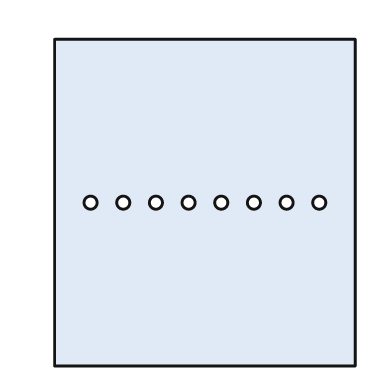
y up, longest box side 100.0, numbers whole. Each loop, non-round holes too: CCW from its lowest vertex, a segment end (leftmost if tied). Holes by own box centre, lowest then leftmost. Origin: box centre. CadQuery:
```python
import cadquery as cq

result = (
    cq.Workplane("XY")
    .moveTo(-46.0, -50.0)
    .lineTo(46.0, -50.0)
    .lineTo(46.0, 50.0)
    .lineTo(-46.0, 50.0)
    .close()
    .moveTo(-35.0, 0.0)
    .circle(2.0)
    .moveTo(-25.0, 0.0)
    .circle(2.0)
    .moveTo(-15.0, 0.0)
    .circle(2.0)
    .moveTo(-5.0, 0.0)
    .circle(2.0)
    .moveTo(5.0, 0.0)
    .circle(2.0)
    .moveTo(15.0, 0.0)
    .circle(2.0)
    .moveTo(25.0, 0.0)
    .circle(2.0)
    .moveTo(35.0, 0.0)
    .circle(2.0)
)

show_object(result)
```